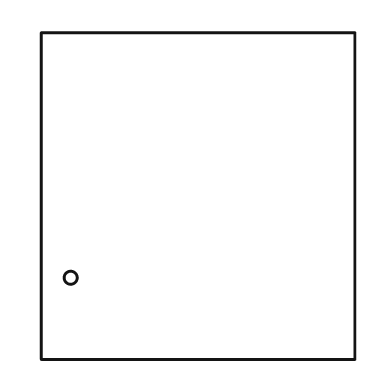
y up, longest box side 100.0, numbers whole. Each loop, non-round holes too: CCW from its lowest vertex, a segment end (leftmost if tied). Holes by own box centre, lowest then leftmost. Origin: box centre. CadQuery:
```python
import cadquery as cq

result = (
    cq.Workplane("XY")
    .moveTo(-48.0, -50.0)
    .lineTo(48.0, -50.0)
    .lineTo(48.0, 50.0)
    .lineTo(-48.0, 50.0)
    .close()
    .moveTo(-39.0, -25.0)
    .circle(2.0)
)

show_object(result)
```